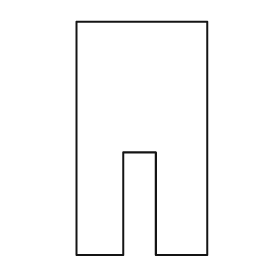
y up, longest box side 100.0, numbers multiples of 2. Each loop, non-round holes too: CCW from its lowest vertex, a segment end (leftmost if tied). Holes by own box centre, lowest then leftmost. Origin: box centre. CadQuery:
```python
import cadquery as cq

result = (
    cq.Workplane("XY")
    .moveTo(-28.0, -50.0)
    .lineTo(-8.0, -50.0)
    .lineTo(-8.0, -6.0)
    .lineTo(6.0, -6.0)
    .lineTo(6.0, -50.0)
    .lineTo(28.0, -50.0)
    .lineTo(28.0, 50.0)
    .lineTo(-28.0, 50.0)
    .close()
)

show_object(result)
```